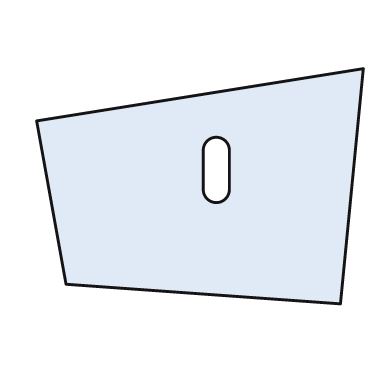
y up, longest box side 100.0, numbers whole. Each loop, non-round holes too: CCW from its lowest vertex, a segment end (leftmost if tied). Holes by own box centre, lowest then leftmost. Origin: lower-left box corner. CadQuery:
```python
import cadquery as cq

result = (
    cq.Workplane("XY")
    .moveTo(93.0, 0.0)
    .lineTo(100.0, 72.0)
    .lineTo(0.0, 56.0)
    .lineTo(9.0, 6.0)
    .close()
    .moveTo(51.0, 35.0)
    .threePointArc((55.0, 31.0), (59.0, 35.0))
    .lineTo(59.0, 47.0)
    .threePointArc((55.0, 51.0), (51.0, 47.0))
    .close()
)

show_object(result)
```